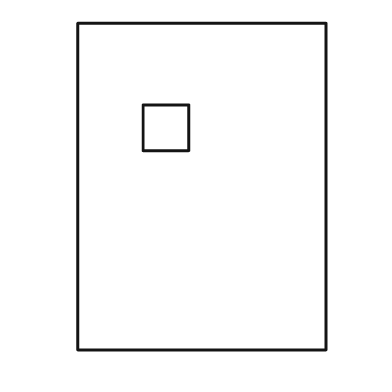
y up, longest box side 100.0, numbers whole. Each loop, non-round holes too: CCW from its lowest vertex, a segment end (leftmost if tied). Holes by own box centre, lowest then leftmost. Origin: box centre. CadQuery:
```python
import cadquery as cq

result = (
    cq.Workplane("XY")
    .moveTo(-38.0, -50.0)
    .lineTo(38.0, -50.0)
    .lineTo(38.0, 50.0)
    .lineTo(-38.0, 50.0)
    .close()
    .moveTo(-18.0, 11.0)
    .lineTo(-4.0, 11.0)
    .lineTo(-4.0, 25.0)
    .lineTo(-18.0, 25.0)
    .close()
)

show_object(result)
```